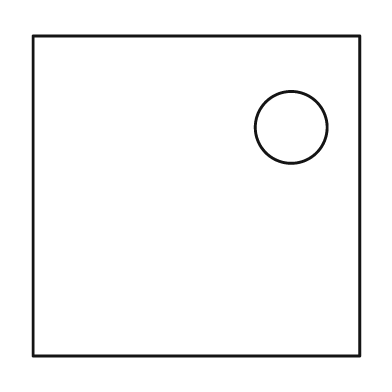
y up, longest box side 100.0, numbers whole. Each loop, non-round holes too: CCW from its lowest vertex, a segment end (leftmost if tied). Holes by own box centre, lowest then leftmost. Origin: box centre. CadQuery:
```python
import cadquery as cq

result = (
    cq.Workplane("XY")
    .moveTo(-50.0, -49.0)
    .lineTo(50.0, -49.0)
    .lineTo(50.0, 49.0)
    .lineTo(-50.0, 49.0)
    .close()
    .moveTo(29.0, 21.0)
    .circle(11.0)
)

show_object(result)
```